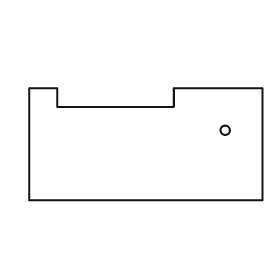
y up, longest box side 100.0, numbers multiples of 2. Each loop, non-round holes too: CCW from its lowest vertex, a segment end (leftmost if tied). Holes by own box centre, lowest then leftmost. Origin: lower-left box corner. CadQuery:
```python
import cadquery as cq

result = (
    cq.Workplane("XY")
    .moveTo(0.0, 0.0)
    .lineTo(100.0, 0.0)
    .lineTo(100.0, 48.0)
    .lineTo(62.0, 48.0)
    .lineTo(62.0, 40.0)
    .lineTo(12.0, 40.0)
    .lineTo(12.0, 48.0)
    .lineTo(0.0, 48.0)
    .close()
    .moveTo(84.0, 30.0)
    .circle(2.0)
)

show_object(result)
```